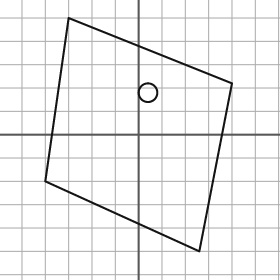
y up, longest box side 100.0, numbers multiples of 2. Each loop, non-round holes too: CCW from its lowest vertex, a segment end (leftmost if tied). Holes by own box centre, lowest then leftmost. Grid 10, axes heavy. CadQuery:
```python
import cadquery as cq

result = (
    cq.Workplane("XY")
    .moveTo(26.0, -50.0)
    .lineTo(40.0, 22.0)
    .lineTo(-30.0, 50.0)
    .lineTo(-40.0, -20.0)
    .close()
    .moveTo(4.0, 18.0)
    .circle(4.0)
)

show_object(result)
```